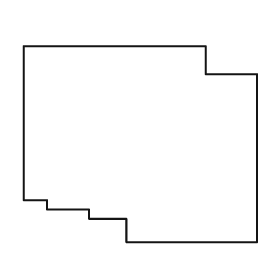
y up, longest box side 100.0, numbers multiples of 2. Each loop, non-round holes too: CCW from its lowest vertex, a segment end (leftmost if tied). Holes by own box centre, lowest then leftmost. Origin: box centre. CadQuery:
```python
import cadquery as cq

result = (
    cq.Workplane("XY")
    .moveTo(-6.0, -42.0)
    .lineTo(50.0, -42.0)
    .lineTo(50.0, 30.0)
    .lineTo(28.0, 30.0)
    .lineTo(28.0, 42.0)
    .lineTo(-50.0, 42.0)
    .lineTo(-50.0, -24.0)
    .lineTo(-40.0, -24.0)
    .lineTo(-40.0, -28.0)
    .lineTo(-22.0, -28.0)
    .lineTo(-22.0, -32.0)
    .lineTo(-6.0, -32.0)
    .close()
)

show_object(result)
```